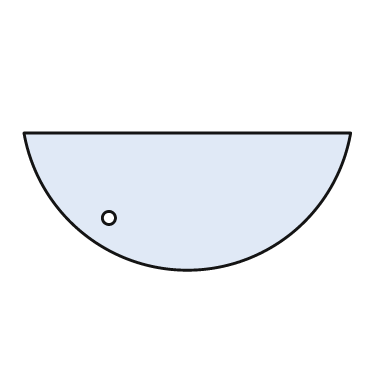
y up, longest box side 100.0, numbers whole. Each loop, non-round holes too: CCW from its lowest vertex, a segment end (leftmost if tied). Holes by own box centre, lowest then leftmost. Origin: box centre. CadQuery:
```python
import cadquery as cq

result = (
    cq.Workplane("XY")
    .moveTo(-50.0, 21.0)
    .threePointArc((0.0, -21.0), (50.0, 21.0))
    .close()
    .moveTo(-24.0, -5.0)
    .circle(2.0)
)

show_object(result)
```